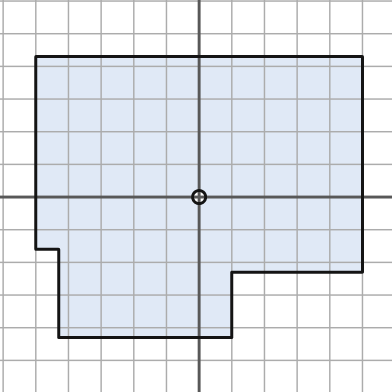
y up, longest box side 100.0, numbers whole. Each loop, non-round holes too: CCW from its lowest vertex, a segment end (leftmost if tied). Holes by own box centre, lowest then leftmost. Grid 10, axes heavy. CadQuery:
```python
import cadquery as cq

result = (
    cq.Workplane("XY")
    .moveTo(-43.0, -43.0)
    .lineTo(10.0, -43.0)
    .lineTo(10.0, -23.0)
    .lineTo(50.0, -23.0)
    .lineTo(50.0, 43.0)
    .lineTo(-50.0, 43.0)
    .lineTo(-50.0, -16.0)
    .lineTo(-43.0, -16.0)
    .close()
    .moveTo(0.0, 0.0)
    .circle(2.0)
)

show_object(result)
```